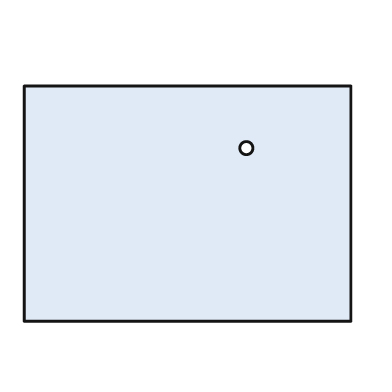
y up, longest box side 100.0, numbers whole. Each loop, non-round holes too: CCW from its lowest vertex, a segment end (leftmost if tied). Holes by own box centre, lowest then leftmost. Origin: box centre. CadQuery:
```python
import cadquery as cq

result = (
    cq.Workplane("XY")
    .moveTo(-50.0, -36.0)
    .lineTo(50.0, -36.0)
    .lineTo(50.0, 36.0)
    .lineTo(-50.0, 36.0)
    .close()
    .moveTo(18.0, 17.0)
    .circle(2.0)
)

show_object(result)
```